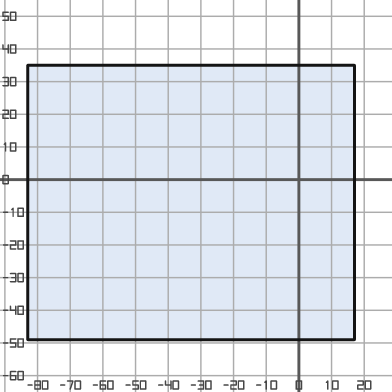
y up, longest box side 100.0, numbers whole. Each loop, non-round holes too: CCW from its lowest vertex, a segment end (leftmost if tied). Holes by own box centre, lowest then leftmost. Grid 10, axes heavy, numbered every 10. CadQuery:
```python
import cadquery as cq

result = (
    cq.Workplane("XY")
    .moveTo(-83.0, -49.0)
    .lineTo(17.0, -49.0)
    .lineTo(17.0, 35.0)
    .lineTo(-83.0, 35.0)
    .close()
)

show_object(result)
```